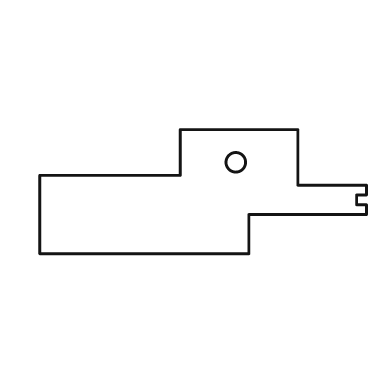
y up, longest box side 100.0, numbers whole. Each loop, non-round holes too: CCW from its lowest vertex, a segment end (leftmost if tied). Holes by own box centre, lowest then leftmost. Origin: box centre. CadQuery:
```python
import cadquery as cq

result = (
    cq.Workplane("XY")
    .moveTo(-50.0, -19.0)
    .lineTo(14.0, -19.0)
    .lineTo(14.0, -7.0)
    .lineTo(50.0, -7.0)
    .lineTo(50.0, -4.0)
    .lineTo(47.0, -4.0)
    .lineTo(47.0, -1.0)
    .lineTo(50.0, -1.0)
    .lineTo(50.0, 2.0)
    .lineTo(29.0, 2.0)
    .lineTo(29.0, 19.0)
    .lineTo(-7.0, 19.0)
    .lineTo(-7.0, 5.0)
    .lineTo(-50.0, 5.0)
    .close()
    .moveTo(10.0, 9.0)
    .circle(3.0)
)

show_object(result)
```